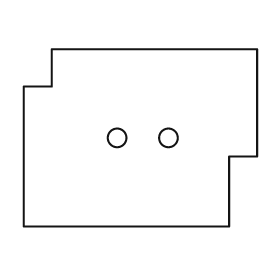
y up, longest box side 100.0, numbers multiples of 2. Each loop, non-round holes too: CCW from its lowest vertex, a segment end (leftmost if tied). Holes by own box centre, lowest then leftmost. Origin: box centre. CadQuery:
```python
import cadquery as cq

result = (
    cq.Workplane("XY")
    .moveTo(-50.0, -38.0)
    .lineTo(38.0, -38.0)
    .lineTo(38.0, -8.0)
    .lineTo(50.0, -8.0)
    .lineTo(50.0, 38.0)
    .lineTo(-38.0, 38.0)
    .lineTo(-38.0, 22.0)
    .lineTo(-50.0, 22.0)
    .close()
    .moveTo(-10.0, 0.0)
    .circle(4.0)
    .moveTo(12.0, 0.0)
    .circle(4.0)
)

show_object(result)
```